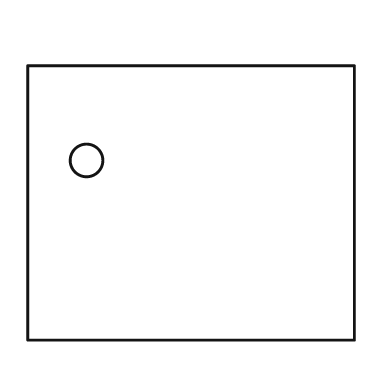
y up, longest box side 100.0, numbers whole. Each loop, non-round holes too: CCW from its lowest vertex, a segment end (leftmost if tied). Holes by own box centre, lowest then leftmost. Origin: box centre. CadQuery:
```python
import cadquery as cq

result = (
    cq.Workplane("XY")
    .moveTo(-50.0, -42.0)
    .lineTo(50.0, -42.0)
    .lineTo(50.0, 42.0)
    .lineTo(-50.0, 42.0)
    .close()
    .moveTo(-32.0, 13.0)
    .circle(5.0)
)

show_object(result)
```